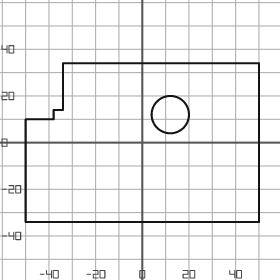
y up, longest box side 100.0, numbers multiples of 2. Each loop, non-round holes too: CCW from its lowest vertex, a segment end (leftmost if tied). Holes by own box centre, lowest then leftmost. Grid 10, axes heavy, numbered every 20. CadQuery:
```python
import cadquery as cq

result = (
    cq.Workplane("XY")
    .moveTo(-50.0, -34.0)
    .lineTo(50.0, -34.0)
    .lineTo(50.0, 34.0)
    .lineTo(-34.0, 34.0)
    .lineTo(-34.0, 14.0)
    .lineTo(-38.0, 14.0)
    .lineTo(-38.0, 10.0)
    .lineTo(-50.0, 10.0)
    .close()
    .moveTo(12.0, 12.0)
    .circle(8.0)
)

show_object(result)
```